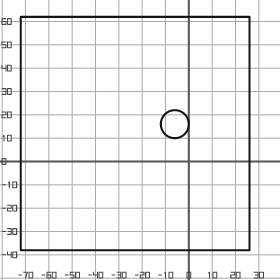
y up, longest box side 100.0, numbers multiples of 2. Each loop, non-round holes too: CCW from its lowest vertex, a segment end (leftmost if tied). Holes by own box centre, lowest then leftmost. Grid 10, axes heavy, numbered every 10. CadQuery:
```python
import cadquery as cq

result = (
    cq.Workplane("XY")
    .moveTo(-72.0, -38.0)
    .lineTo(26.0, -38.0)
    .lineTo(26.0, 62.0)
    .lineTo(-72.0, 62.0)
    .close()
    .moveTo(-6.0, 16.0)
    .circle(6.0)
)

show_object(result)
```